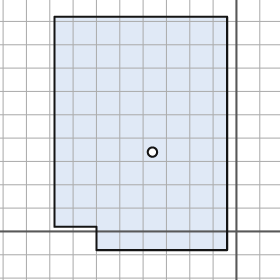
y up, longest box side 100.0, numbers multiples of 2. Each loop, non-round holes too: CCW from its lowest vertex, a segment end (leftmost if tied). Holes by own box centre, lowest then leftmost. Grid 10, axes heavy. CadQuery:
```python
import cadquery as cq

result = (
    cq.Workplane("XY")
    .moveTo(-60.0, -8.0)
    .lineTo(-4.0, -8.0)
    .lineTo(-4.0, 92.0)
    .lineTo(-78.0, 92.0)
    .lineTo(-78.0, 2.0)
    .lineTo(-60.0, 2.0)
    .close()
    .moveTo(-36.0, 34.0)
    .circle(2.0)
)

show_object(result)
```